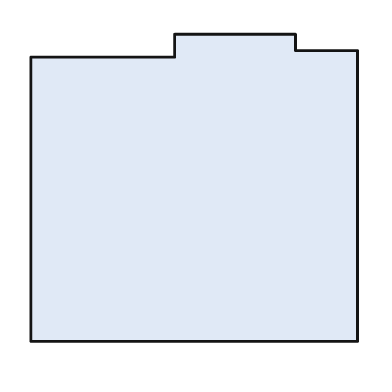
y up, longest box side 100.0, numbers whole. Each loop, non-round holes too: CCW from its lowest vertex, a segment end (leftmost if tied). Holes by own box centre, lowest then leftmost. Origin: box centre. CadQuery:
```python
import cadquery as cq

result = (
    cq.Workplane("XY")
    .moveTo(-50.0, -47.0)
    .lineTo(50.0, -47.0)
    .lineTo(50.0, 42.0)
    .lineTo(31.0, 42.0)
    .lineTo(31.0, 47.0)
    .lineTo(-6.0, 47.0)
    .lineTo(-6.0, 40.0)
    .lineTo(-50.0, 40.0)
    .close()
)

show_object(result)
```